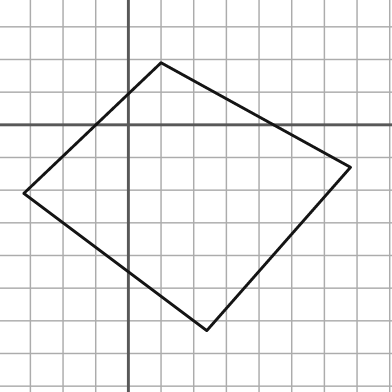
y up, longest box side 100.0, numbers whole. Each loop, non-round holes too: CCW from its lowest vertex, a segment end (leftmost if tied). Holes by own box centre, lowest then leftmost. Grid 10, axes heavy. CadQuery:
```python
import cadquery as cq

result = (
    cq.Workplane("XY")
    .moveTo(24.0, -63.0)
    .lineTo(68.0, -13.0)
    .lineTo(10.0, 19.0)
    .lineTo(-32.0, -21.0)
    .close()
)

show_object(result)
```